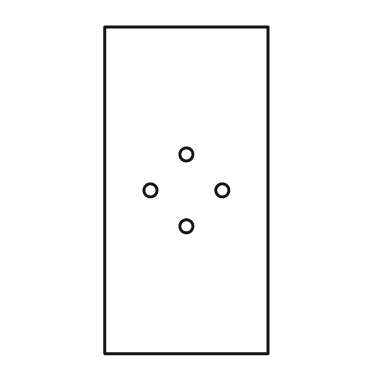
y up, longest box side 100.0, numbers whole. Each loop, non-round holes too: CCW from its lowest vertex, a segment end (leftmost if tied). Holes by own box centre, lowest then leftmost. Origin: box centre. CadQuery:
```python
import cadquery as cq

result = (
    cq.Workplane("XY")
    .moveTo(-25.0, -50.0)
    .lineTo(25.0, -50.0)
    .lineTo(25.0, 50.0)
    .lineTo(-25.0, 50.0)
    .close()
    .moveTo(0.0, -11.0)
    .circle(2.0)
    .moveTo(-11.0, 0.0)
    .circle(2.0)
    .moveTo(11.0, 0.0)
    .circle(2.0)
    .moveTo(0.0, 11.0)
    .circle(2.0)
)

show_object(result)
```